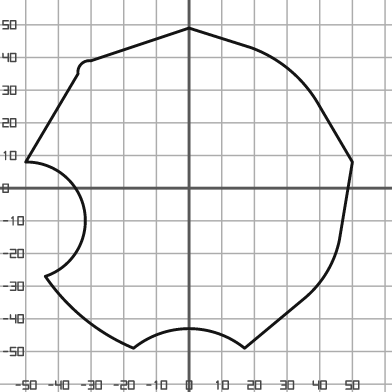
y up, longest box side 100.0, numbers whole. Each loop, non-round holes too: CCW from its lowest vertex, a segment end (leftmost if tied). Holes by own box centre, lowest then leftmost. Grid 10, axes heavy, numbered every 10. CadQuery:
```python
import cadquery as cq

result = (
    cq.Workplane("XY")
    .moveTo(-17.0, -49.0)
    .threePointArc((0.0, -43.0), (17.0, -49.0))
    .lineTo(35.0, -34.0)
    .threePointArc((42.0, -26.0), (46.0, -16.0))
    .lineTo(50.0, 8.0)
    .lineTo(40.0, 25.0)
    .threePointArc((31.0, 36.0), (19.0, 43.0))
    .lineTo(0.0, 49.0)
    .lineTo(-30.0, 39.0)
    .threePointArc((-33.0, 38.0), (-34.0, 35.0))
    .lineTo(-50.0, 8.0)
    .threePointArc((-32.0, -7.0), (-44.0, -27.0))
    .threePointArc((-32.0, -40.0), (-17.0, -49.0))
    .close()
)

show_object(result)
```